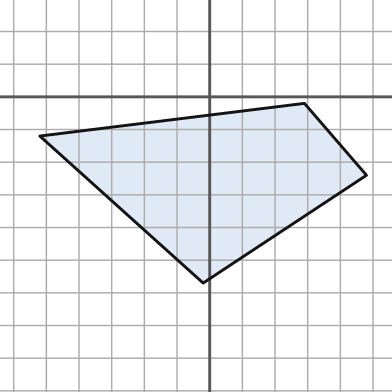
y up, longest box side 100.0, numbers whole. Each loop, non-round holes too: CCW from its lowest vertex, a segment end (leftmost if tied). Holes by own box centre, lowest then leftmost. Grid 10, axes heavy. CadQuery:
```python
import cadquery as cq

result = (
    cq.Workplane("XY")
    .moveTo(-2.0, -57.0)
    .lineTo(48.0, -24.0)
    .lineTo(29.0, -2.0)
    .lineTo(-52.0, -12.0)
    .close()
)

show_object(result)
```